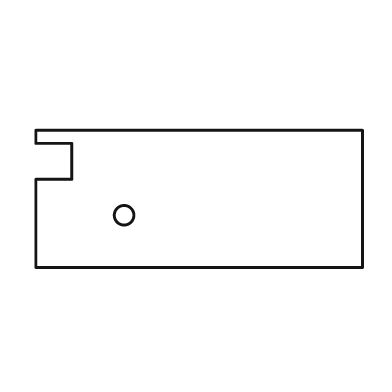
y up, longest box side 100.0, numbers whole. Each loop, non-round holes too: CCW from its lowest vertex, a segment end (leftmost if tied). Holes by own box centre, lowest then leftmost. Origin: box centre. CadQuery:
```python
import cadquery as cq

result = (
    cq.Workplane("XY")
    .moveTo(-50.0, -21.0)
    .lineTo(50.0, -21.0)
    .lineTo(50.0, 21.0)
    .lineTo(-50.0, 21.0)
    .lineTo(-50.0, 17.0)
    .lineTo(-39.0, 17.0)
    .lineTo(-39.0, 6.0)
    .lineTo(-50.0, 6.0)
    .close()
    .moveTo(-23.0, -5.0)
    .circle(3.0)
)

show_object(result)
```